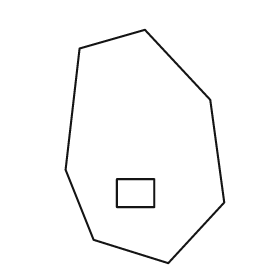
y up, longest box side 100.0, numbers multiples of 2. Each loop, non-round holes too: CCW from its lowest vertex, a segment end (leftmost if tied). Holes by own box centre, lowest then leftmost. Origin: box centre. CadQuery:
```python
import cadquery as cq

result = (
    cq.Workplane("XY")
    .moveTo(10.0, -50.0)
    .lineTo(34.0, -24.0)
    .lineTo(28.0, 20.0)
    .lineTo(0.0, 50.0)
    .lineTo(-28.0, 42.0)
    .lineTo(-34.0, -10.0)
    .lineTo(-22.0, -40.0)
    .close()
    .moveTo(-12.0, -26.0)
    .lineTo(4.0, -26.0)
    .lineTo(4.0, -14.0)
    .lineTo(-12.0, -14.0)
    .close()
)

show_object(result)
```